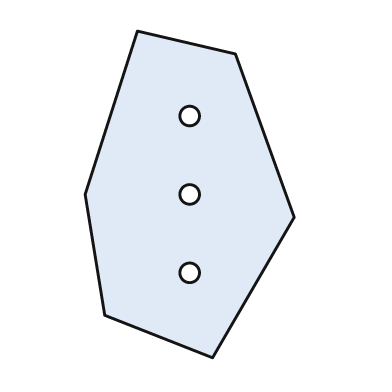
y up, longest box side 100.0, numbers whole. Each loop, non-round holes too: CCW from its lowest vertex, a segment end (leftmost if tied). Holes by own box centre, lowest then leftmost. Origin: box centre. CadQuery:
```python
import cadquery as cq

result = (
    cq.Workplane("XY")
    .moveTo(7.0, -50.0)
    .lineTo(32.0, -7.0)
    .lineTo(14.0, 43.0)
    .lineTo(-16.0, 50.0)
    .lineTo(-32.0, 0.0)
    .lineTo(-26.0, -37.0)
    .close()
    .moveTo(0.0, -24.0)
    .circle(3.0)
    .moveTo(0.0, 0.0)
    .circle(3.0)
    .moveTo(0.0, 24.0)
    .circle(3.0)
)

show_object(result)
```